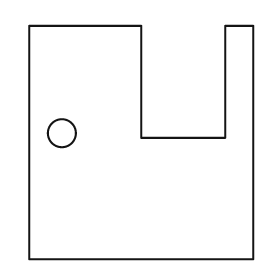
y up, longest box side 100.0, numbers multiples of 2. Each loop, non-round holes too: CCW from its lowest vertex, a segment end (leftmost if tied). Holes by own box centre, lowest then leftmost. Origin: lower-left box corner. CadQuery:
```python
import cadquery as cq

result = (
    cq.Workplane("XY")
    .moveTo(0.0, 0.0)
    .lineTo(96.0, 0.0)
    .lineTo(96.0, 100.0)
    .lineTo(84.0, 100.0)
    .lineTo(84.0, 52.0)
    .lineTo(48.0, 52.0)
    .lineTo(48.0, 100.0)
    .lineTo(0.0, 100.0)
    .close()
    .moveTo(14.0, 54.0)
    .circle(6.0)
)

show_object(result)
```